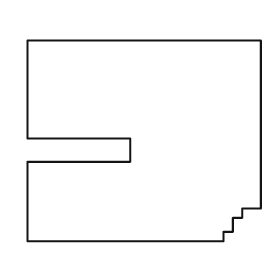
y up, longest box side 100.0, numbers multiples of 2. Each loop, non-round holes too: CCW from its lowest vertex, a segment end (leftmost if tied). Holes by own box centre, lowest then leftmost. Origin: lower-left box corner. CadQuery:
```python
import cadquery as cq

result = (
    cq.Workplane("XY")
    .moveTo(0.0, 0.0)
    .lineTo(84.0, 0.0)
    .lineTo(84.0, 4.0)
    .lineTo(88.0, 4.0)
    .lineTo(88.0, 10.0)
    .lineTo(92.0, 10.0)
    .lineTo(92.0, 14.0)
    .lineTo(100.0, 14.0)
    .lineTo(100.0, 86.0)
    .lineTo(0.0, 86.0)
    .lineTo(0.0, 44.0)
    .lineTo(44.0, 44.0)
    .lineTo(44.0, 34.0)
    .lineTo(0.0, 34.0)
    .close()
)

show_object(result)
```